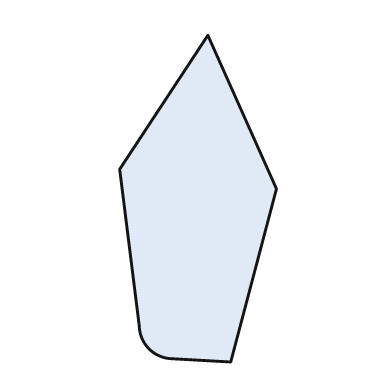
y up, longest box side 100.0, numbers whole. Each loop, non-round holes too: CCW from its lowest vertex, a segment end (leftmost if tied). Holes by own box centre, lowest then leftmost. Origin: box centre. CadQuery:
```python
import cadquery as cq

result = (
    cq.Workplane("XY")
    .moveTo(10.0, -50.0)
    .lineTo(24.0, 3.0)
    .lineTo(3.0, 50.0)
    .lineTo(-24.0, 9.0)
    .lineTo(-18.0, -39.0)
    .threePointArc((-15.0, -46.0), (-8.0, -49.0))
    .close()
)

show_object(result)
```